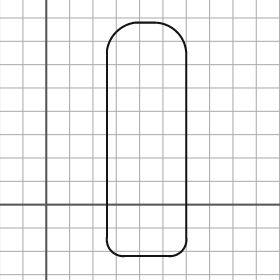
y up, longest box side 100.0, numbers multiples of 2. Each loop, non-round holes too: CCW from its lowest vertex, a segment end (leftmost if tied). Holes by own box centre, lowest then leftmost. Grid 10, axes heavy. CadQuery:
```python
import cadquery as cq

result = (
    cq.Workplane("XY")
    .moveTo(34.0, -22.0)
    .lineTo(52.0, -22.0)
    .threePointArc((58.0, -20.0), (60.0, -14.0))
    .lineTo(60.0, 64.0)
    .threePointArc((56.0, 74.0), (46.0, 78.0))
    .lineTo(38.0, 78.0)
    .threePointArc((30.0, 74.0), (26.0, 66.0))
    .lineTo(26.0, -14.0)
    .threePointArc((28.0, -20.0), (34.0, -22.0))
    .close()
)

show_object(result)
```